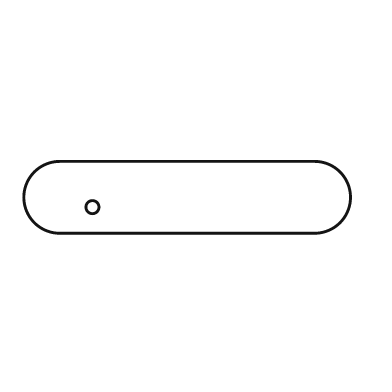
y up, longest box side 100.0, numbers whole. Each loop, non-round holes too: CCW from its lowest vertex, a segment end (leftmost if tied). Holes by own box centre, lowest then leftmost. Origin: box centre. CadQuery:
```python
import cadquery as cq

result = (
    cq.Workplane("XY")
    .moveTo(-39.0, -11.0)
    .lineTo(39.0, -11.0)
    .threePointArc((50.0, 0.0), (39.0, 11.0))
    .lineTo(-39.0, 11.0)
    .threePointArc((-50.0, 0.0), (-39.0, -11.0))
    .close()
    .moveTo(-29.0, -3.0)
    .circle(2.0)
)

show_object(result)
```